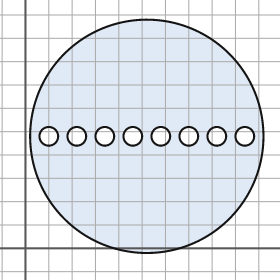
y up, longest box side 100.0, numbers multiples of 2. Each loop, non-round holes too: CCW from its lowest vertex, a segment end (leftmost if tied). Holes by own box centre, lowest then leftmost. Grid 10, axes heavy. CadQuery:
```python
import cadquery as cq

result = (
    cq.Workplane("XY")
    .moveTo(52.0, 48.0)
    .circle(50.0)
    .moveTo(10.0, 48.0)
    .circle(4.0)
    .moveTo(22.0, 48.0)
    .circle(4.0)
    .moveTo(34.0, 48.0)
    .circle(4.0)
    .moveTo(46.0, 48.0)
    .circle(4.0)
    .moveTo(58.0, 48.0)
    .circle(4.0)
    .moveTo(70.0, 48.0)
    .circle(4.0)
    .moveTo(82.0, 48.0)
    .circle(4.0)
    .moveTo(94.0, 48.0)
    .circle(4.0)
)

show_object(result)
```